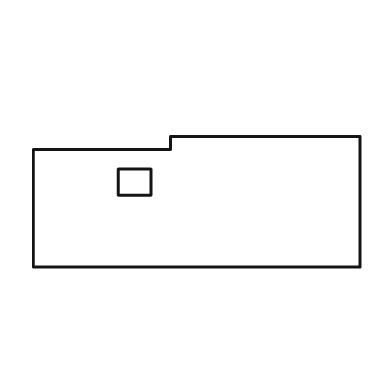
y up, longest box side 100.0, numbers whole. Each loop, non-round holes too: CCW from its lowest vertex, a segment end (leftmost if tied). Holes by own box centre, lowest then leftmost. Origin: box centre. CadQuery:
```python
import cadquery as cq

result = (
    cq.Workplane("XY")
    .moveTo(-50.0, -20.0)
    .lineTo(50.0, -20.0)
    .lineTo(50.0, 20.0)
    .lineTo(-8.0, 20.0)
    .lineTo(-8.0, 16.0)
    .lineTo(-50.0, 16.0)
    .close()
    .moveTo(-24.0, 2.0)
    .lineTo(-14.0, 2.0)
    .lineTo(-14.0, 10.0)
    .lineTo(-24.0, 10.0)
    .close()
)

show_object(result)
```